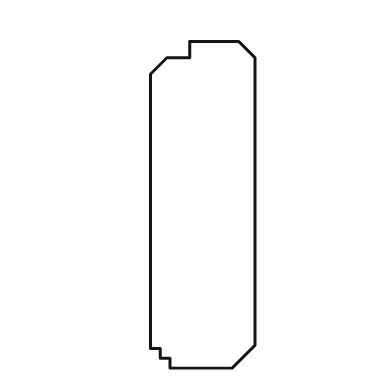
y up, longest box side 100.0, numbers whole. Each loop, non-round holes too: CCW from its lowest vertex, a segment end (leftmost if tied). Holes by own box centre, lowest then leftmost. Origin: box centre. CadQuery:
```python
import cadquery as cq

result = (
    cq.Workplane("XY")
    .moveTo(-10.0, -50.0)
    .lineTo(9.0, -50.0)
    .lineTo(16.0, -43.0)
    .lineTo(16.0, 45.0)
    .lineTo(11.0, 50.0)
    .lineTo(-4.0, 50.0)
    .lineTo(-4.0, 45.0)
    .lineTo(-11.0, 45.0)
    .lineTo(-16.0, 40.0)
    .lineTo(-16.0, -44.0)
    .lineTo(-13.0, -44.0)
    .lineTo(-13.0, -47.0)
    .lineTo(-10.0, -47.0)
    .close()
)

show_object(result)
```